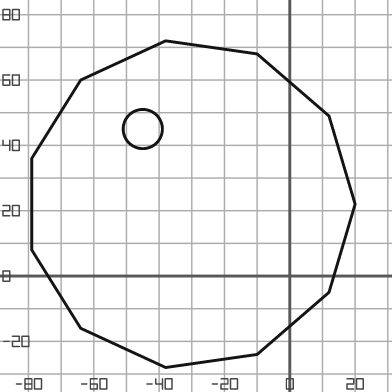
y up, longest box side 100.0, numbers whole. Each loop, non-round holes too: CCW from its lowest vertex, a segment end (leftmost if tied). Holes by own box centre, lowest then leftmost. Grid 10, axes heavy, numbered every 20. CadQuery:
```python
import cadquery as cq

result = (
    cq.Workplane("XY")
    .moveTo(-38.0, -28.0)
    .lineTo(-10.0, -24.0)
    .lineTo(12.0, -5.0)
    .lineTo(20.0, 22.0)
    .lineTo(12.0, 49.0)
    .lineTo(-10.0, 68.0)
    .lineTo(-38.0, 72.0)
    .lineTo(-64.0, 60.0)
    .lineTo(-79.0, 36.0)
    .lineTo(-79.0, 8.0)
    .lineTo(-64.0, -16.0)
    .close()
    .moveTo(-45.0, 45.0)
    .circle(6.0)
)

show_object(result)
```